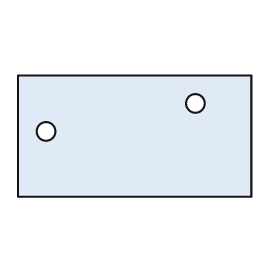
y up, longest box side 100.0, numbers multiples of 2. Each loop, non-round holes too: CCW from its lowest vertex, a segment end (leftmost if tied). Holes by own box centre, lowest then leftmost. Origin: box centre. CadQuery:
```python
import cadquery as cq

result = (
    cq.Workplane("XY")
    .moveTo(-50.0, -26.0)
    .lineTo(50.0, -26.0)
    .lineTo(50.0, 26.0)
    .lineTo(-50.0, 26.0)
    .close()
    .moveTo(-38.0, 2.0)
    .circle(4.0)
    .moveTo(26.0, 14.0)
    .circle(4.0)
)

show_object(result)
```